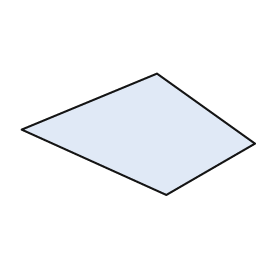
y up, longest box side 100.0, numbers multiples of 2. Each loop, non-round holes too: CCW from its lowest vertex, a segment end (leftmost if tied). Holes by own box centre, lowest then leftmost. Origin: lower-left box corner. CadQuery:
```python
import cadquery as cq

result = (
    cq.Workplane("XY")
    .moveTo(62.0, 0.0)
    .lineTo(100.0, 22.0)
    .lineTo(58.0, 52.0)
    .lineTo(0.0, 28.0)
    .close()
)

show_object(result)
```